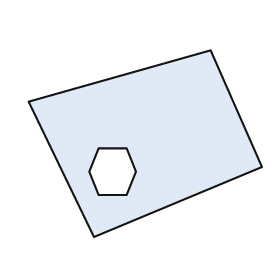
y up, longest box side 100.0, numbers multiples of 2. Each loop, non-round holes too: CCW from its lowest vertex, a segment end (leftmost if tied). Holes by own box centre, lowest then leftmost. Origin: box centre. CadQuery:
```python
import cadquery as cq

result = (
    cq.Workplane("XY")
    .moveTo(-22.0, -40.0)
    .lineTo(50.0, -10.0)
    .lineTo(28.0, 40.0)
    .lineTo(-50.0, 18.0)
    .close()
    .moveTo(-20.0, -22.0)
    .lineTo(-8.0, -22.0)
    .lineTo(-4.0, -12.0)
    .lineTo(-8.0, -2.0)
    .lineTo(-20.0, -2.0)
    .lineTo(-24.0, -12.0)
    .close()
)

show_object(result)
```